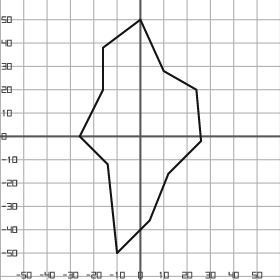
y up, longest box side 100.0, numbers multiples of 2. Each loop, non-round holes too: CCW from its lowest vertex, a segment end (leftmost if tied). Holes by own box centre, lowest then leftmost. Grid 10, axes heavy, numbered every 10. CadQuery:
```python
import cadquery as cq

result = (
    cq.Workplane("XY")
    .moveTo(-10.0, -50.0)
    .lineTo(4.0, -36.0)
    .lineTo(12.0, -16.0)
    .lineTo(26.0, -2.0)
    .lineTo(24.0, 20.0)
    .lineTo(10.0, 28.0)
    .lineTo(0.0, 50.0)
    .lineTo(-16.0, 38.0)
    .lineTo(-16.0, 20.0)
    .lineTo(-26.0, 0.0)
    .lineTo(-14.0, -12.0)
    .close()
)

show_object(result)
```